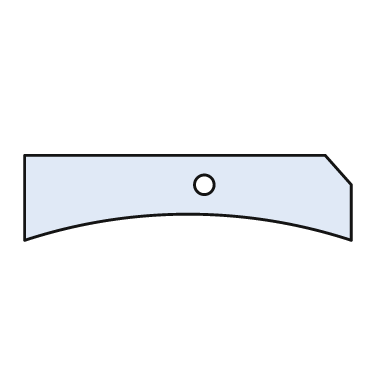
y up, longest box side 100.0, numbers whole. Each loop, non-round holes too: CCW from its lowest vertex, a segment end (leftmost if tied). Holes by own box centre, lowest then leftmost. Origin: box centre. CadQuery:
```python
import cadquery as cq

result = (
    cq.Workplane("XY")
    .moveTo(-50.0, -13.0)
    .threePointArc((0.0, -5.0), (50.0, -13.0))
    .lineTo(50.0, 4.0)
    .lineTo(42.0, 13.0)
    .lineTo(-50.0, 13.0)
    .close()
    .moveTo(5.0, 4.0)
    .circle(3.0)
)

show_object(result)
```